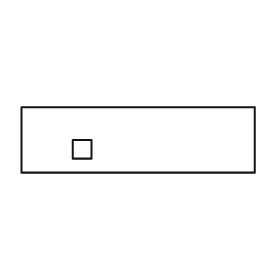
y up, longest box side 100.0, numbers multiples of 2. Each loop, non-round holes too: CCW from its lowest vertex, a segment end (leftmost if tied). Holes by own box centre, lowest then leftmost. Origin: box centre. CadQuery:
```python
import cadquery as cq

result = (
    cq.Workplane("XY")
    .moveTo(-50.0, -14.0)
    .lineTo(50.0, -14.0)
    .lineTo(50.0, 14.0)
    .lineTo(-50.0, 14.0)
    .close()
    .moveTo(-28.0, -8.0)
    .lineTo(-20.0, -8.0)
    .lineTo(-20.0, 0.0)
    .lineTo(-28.0, 0.0)
    .close()
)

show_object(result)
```